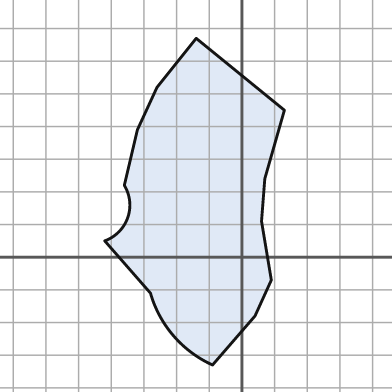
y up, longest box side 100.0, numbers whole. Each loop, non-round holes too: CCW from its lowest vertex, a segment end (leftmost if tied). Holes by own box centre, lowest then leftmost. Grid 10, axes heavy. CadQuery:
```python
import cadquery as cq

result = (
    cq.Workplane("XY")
    .moveTo(-9.0, -33.0)
    .lineTo(4.0, -18.0)
    .lineTo(9.0, -7.0)
    .lineTo(6.0, 11.0)
    .lineTo(7.0, 24.0)
    .lineTo(13.0, 45.0)
    .lineTo(-14.0, 67.0)
    .lineTo(-26.0, 52.0)
    .lineTo(-32.0, 39.0)
    .lineTo(-36.0, 22.0)
    .threePointArc((-35.0, 12.0), (-42.0, 5.0))
    .lineTo(-28.0, -11.0)
    .threePointArc((-21.0, -24.0), (-9.0, -33.0))
    .close()
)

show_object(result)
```